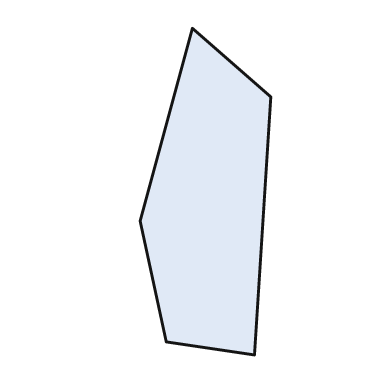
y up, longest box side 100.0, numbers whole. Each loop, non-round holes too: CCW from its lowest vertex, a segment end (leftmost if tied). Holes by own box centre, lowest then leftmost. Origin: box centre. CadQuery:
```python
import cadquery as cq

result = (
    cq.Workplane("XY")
    .moveTo(15.0, -50.0)
    .lineTo(20.0, 29.0)
    .lineTo(-4.0, 50.0)
    .lineTo(-20.0, -9.0)
    .lineTo(-12.0, -46.0)
    .close()
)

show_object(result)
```